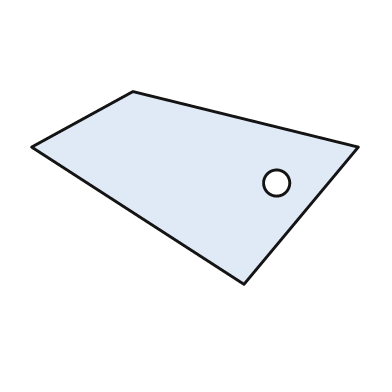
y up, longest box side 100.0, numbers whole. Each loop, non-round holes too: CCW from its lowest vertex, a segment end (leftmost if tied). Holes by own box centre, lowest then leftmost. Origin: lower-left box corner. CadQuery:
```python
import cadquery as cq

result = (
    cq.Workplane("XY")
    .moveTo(65.0, 0.0)
    .lineTo(100.0, 42.0)
    .lineTo(31.0, 59.0)
    .lineTo(0.0, 42.0)
    .close()
    .moveTo(75.0, 31.0)
    .circle(4.0)
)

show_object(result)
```